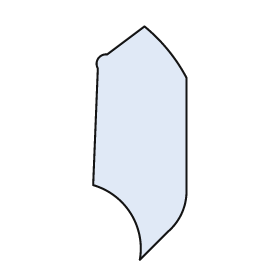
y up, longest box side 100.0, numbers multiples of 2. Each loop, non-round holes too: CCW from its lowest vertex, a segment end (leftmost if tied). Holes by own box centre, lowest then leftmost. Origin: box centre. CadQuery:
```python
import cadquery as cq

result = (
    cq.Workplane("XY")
    .moveTo(0.0, -50.0)
    .lineTo(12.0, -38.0)
    .threePointArc((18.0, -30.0), (20.0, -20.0))
    .lineTo(20.0, 28.0)
    .threePointArc((12.0, 40.0), (2.0, 50.0))
    .lineTo(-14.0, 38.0)
    .threePointArc((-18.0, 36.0), (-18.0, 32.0))
    .lineTo(-20.0, -18.0)
    .threePointArc((-4.0, -30.0), (0.0, -50.0))
    .close()
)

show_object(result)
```